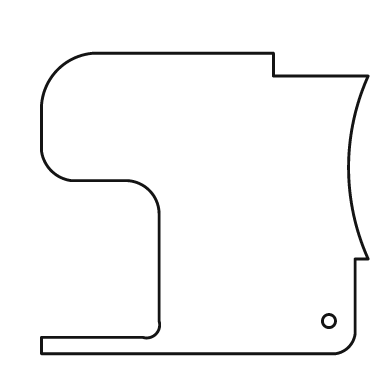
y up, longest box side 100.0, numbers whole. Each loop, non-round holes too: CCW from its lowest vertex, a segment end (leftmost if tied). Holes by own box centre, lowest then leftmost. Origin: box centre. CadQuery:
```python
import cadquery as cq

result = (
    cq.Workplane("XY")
    .moveTo(-50.0, -46.0)
    .lineTo(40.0, -46.0)
    .threePointArc((44.0, -44.0), (46.0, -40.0))
    .lineTo(46.0, -17.0)
    .lineTo(50.0, -17.0)
    .threePointArc((44.0, 11.0), (50.0, 39.0))
    .lineTo(21.0, 39.0)
    .lineTo(21.0, 46.0)
    .lineTo(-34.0, 46.0)
    .threePointArc((-45.0, 41.0), (-50.0, 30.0))
    .lineTo(-50.0, 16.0)
    .threePointArc((-47.0, 10.0), (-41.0, 7.0))
    .lineTo(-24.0, 7.0)
    .threePointArc((-17.0, 4.0), (-14.0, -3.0))
    .lineTo(-14.0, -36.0)
    .threePointArc((-15.0, -40.0), (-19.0, -41.0))
    .lineTo(-50.0, -41.0)
    .close()
    .moveTo(38.0, -36.0)
    .circle(2.0)
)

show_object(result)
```